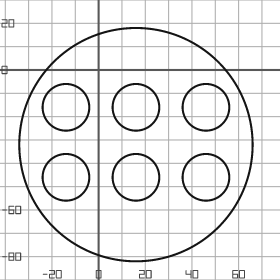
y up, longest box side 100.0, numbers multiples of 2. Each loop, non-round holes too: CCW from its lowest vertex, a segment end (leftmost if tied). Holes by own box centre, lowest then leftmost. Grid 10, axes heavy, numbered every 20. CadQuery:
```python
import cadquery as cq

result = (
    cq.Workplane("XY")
    .moveTo(16.0, -32.0)
    .circle(50.0)
    .moveTo(-14.0, -46.0)
    .circle(10.0)
    .moveTo(16.0, -46.0)
    .circle(10.0)
    .moveTo(46.0, -46.0)
    .circle(10.0)
    .moveTo(-14.0, -16.0)
    .circle(10.0)
    .moveTo(16.0, -16.0)
    .circle(10.0)
    .moveTo(46.0, -16.0)
    .circle(10.0)
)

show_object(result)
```